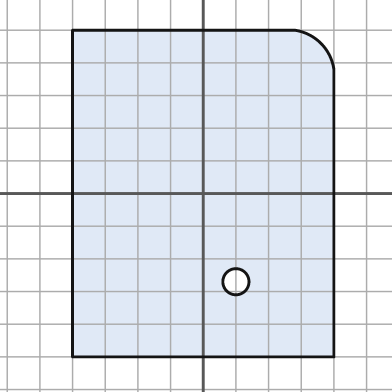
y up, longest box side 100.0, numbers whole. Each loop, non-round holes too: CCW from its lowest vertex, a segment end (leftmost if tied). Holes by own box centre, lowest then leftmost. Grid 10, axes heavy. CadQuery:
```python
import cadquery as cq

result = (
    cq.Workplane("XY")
    .moveTo(-40.0, -50.0)
    .lineTo(40.0, -50.0)
    .lineTo(40.0, 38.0)
    .threePointArc((36.0, 46.0), (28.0, 50.0))
    .lineTo(-40.0, 50.0)
    .close()
    .moveTo(10.0, -27.0)
    .circle(4.0)
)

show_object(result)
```